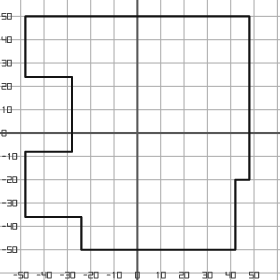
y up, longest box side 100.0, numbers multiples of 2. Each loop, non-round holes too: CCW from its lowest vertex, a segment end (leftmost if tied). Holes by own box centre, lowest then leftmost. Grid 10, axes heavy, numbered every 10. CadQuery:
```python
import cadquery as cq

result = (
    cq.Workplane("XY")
    .moveTo(-24.0, -50.0)
    .lineTo(42.0, -50.0)
    .lineTo(42.0, -20.0)
    .lineTo(48.0, -20.0)
    .lineTo(48.0, 50.0)
    .lineTo(-48.0, 50.0)
    .lineTo(-48.0, 24.0)
    .lineTo(-28.0, 24.0)
    .lineTo(-28.0, -8.0)
    .lineTo(-48.0, -8.0)
    .lineTo(-48.0, -36.0)
    .lineTo(-24.0, -36.0)
    .close()
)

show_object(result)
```